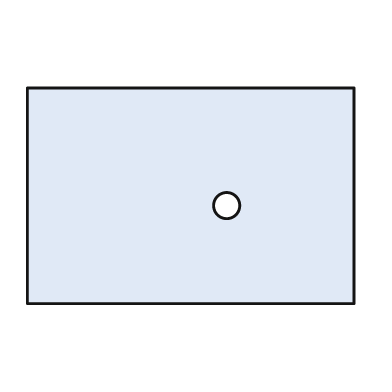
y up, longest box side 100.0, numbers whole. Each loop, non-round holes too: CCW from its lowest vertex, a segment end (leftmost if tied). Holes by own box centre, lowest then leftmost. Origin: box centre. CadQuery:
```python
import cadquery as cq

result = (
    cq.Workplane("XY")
    .moveTo(-50.0, -33.0)
    .lineTo(50.0, -33.0)
    .lineTo(50.0, 33.0)
    .lineTo(-50.0, 33.0)
    .close()
    .moveTo(11.0, -3.0)
    .circle(4.0)
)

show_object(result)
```